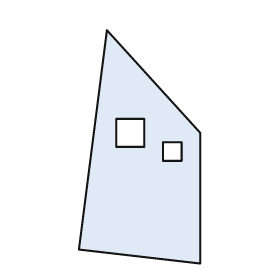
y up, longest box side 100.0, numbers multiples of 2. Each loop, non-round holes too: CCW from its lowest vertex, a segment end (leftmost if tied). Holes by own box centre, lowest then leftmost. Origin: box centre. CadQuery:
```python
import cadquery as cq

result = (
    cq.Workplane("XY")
    .moveTo(26.0, -50.0)
    .lineTo(26.0, 6.0)
    .lineTo(-14.0, 50.0)
    .lineTo(-26.0, -44.0)
    .close()
    .moveTo(10.0, -6.0)
    .lineTo(18.0, -6.0)
    .lineTo(18.0, 2.0)
    .lineTo(10.0, 2.0)
    .close()
    .moveTo(-10.0, 0.0)
    .lineTo(2.0, 0.0)
    .lineTo(2.0, 12.0)
    .lineTo(-10.0, 12.0)
    .close()
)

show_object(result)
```